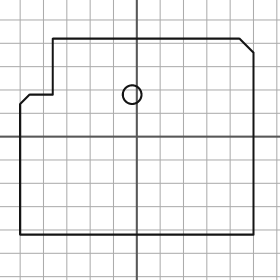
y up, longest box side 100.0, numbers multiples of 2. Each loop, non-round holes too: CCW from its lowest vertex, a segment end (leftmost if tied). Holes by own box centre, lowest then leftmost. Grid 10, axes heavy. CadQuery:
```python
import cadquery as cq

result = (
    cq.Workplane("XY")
    .moveTo(-50.0, -42.0)
    .lineTo(50.0, -42.0)
    .lineTo(50.0, 36.0)
    .lineTo(44.0, 42.0)
    .lineTo(-36.0, 42.0)
    .lineTo(-36.0, 18.0)
    .lineTo(-46.0, 18.0)
    .lineTo(-50.0, 14.0)
    .close()
    .moveTo(-2.0, 18.0)
    .circle(4.0)
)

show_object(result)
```